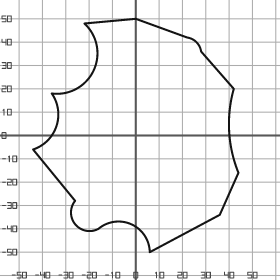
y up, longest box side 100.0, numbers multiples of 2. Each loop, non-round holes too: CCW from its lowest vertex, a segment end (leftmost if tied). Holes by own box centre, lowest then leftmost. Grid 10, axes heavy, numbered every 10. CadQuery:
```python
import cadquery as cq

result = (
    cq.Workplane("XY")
    .moveTo(6.0, -50.0)
    .lineTo(36.0, -34.0)
    .lineTo(44.0, -16.0)
    .threePointArc((40.0, 2.0), (42.0, 20.0))
    .lineTo(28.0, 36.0)
    .threePointArc((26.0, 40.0), (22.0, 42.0))
    .lineTo(0.0, 50.0)
    .lineTo(-22.0, 48.0)
    .threePointArc((-18.0, 28.0), (-36.0, 18.0))
    .threePointArc((-34.0, 4.0), (-44.0, -6.0))
    .lineTo(-26.0, -28.0)
    .threePointArc((-26.0, -38.0), (-16.0, -40.0))
    .threePointArc((-2.0, -38.0), (6.0, -50.0))
    .close()
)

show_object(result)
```